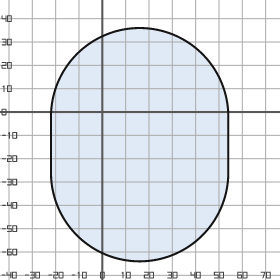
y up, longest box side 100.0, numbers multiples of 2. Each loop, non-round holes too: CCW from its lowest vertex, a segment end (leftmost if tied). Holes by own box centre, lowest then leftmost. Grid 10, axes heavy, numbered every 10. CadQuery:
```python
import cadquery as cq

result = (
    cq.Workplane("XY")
    .moveTo(-22.0, -26.0)
    .threePointArc((16.0, -64.0), (54.0, -26.0))
    .lineTo(54.0, -2.0)
    .threePointArc((16.0, 36.0), (-22.0, -2.0))
    .close()
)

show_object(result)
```